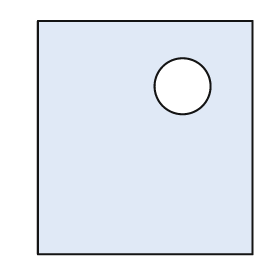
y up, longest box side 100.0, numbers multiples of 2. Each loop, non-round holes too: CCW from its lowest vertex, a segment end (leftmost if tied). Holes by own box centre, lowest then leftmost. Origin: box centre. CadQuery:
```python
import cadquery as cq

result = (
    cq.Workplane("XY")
    .moveTo(-46.0, -50.0)
    .lineTo(46.0, -50.0)
    .lineTo(46.0, 50.0)
    .lineTo(-46.0, 50.0)
    .close()
    .moveTo(16.0, 22.0)
    .circle(12.0)
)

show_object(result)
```